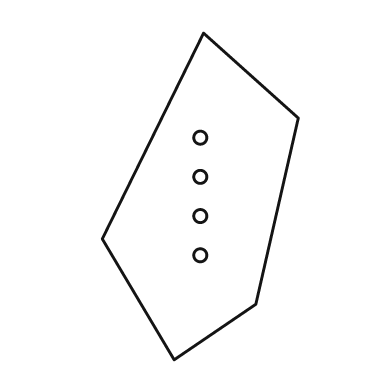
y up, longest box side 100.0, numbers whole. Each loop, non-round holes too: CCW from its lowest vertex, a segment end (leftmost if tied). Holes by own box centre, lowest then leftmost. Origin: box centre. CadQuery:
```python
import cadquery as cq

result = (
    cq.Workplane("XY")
    .moveTo(-8.0, -50.0)
    .lineTo(17.0, -33.0)
    .lineTo(30.0, 24.0)
    .lineTo(1.0, 50.0)
    .lineTo(-30.0, -13.0)
    .close()
    .moveTo(0.0, -18.0)
    .circle(2.0)
    .moveTo(0.0, -6.0)
    .circle(2.0)
    .moveTo(0.0, 6.0)
    .circle(2.0)
    .moveTo(0.0, 18.0)
    .circle(2.0)
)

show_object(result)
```